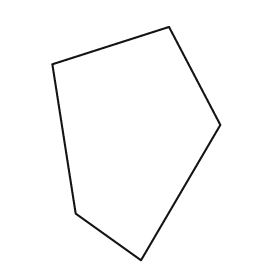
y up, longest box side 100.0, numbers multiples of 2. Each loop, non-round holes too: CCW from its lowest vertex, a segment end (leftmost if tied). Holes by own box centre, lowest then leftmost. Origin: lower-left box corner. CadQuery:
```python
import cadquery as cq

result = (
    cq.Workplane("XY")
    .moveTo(38.0, 0.0)
    .lineTo(72.0, 58.0)
    .lineTo(50.0, 100.0)
    .lineTo(0.0, 84.0)
    .lineTo(10.0, 20.0)
    .close()
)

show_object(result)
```